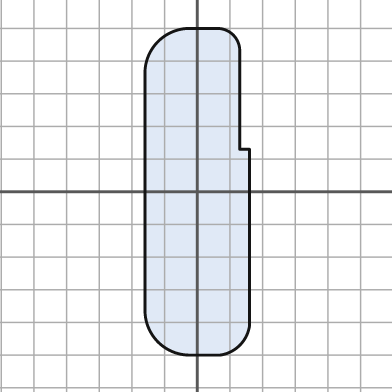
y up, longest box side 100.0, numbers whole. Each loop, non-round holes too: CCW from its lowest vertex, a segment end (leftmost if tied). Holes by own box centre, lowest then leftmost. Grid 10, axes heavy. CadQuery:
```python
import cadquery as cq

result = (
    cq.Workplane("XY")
    .moveTo(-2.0, -50.0)
    .lineTo(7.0, -50.0)
    .threePointArc((13.0, -47.0), (16.0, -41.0))
    .lineTo(16.0, 13.0)
    .lineTo(13.0, 13.0)
    .lineTo(13.0, 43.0)
    .threePointArc((11.0, 48.0), (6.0, 50.0))
    .lineTo(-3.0, 50.0)
    .threePointArc((-12.0, 46.0), (-16.0, 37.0))
    .lineTo(-16.0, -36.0)
    .threePointArc((-12.0, -46.0), (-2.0, -50.0))
    .close()
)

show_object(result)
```